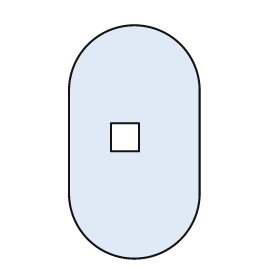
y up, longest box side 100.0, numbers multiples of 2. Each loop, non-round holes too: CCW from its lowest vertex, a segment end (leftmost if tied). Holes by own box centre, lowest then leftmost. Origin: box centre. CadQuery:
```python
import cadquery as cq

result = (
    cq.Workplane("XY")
    .moveTo(-28.0, -22.0)
    .threePointArc((0.0, -50.0), (28.0, -22.0))
    .lineTo(28.0, 22.0)
    .threePointArc((0.0, 50.0), (-28.0, 22.0))
    .close()
    .moveTo(-10.0, -4.0)
    .lineTo(2.0, -4.0)
    .lineTo(2.0, 8.0)
    .lineTo(-10.0, 8.0)
    .close()
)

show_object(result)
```